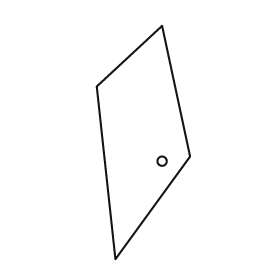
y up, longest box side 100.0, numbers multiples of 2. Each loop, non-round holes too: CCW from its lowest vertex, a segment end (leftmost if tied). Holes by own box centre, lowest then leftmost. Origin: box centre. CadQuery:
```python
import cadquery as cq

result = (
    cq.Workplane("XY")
    .moveTo(-12.0, -50.0)
    .lineTo(20.0, -6.0)
    .lineTo(8.0, 50.0)
    .lineTo(-20.0, 24.0)
    .close()
    .moveTo(8.0, -8.0)
    .circle(2.0)
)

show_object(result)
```